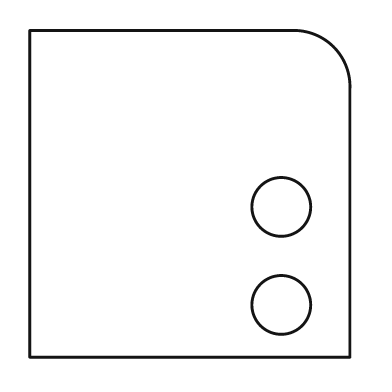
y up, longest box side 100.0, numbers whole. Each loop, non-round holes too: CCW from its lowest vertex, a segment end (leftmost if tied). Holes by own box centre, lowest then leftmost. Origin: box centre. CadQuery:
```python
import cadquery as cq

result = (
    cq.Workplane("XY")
    .moveTo(-49.0, -50.0)
    .lineTo(49.0, -50.0)
    .lineTo(49.0, 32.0)
    .threePointArc((44.0, 45.0), (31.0, 50.0))
    .lineTo(-49.0, 50.0)
    .close()
    .moveTo(28.0, -34.0)
    .circle(9.0)
    .moveTo(28.0, -4.0)
    .circle(9.0)
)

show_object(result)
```